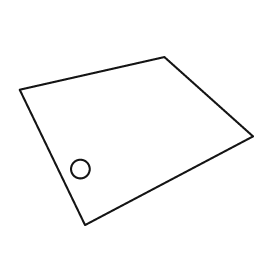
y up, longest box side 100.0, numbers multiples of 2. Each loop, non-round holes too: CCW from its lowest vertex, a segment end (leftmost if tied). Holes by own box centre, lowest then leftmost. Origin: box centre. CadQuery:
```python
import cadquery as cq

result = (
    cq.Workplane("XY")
    .moveTo(-22.0, -36.0)
    .lineTo(50.0, 2.0)
    .lineTo(12.0, 36.0)
    .lineTo(-50.0, 22.0)
    .close()
    .moveTo(-24.0, -12.0)
    .circle(4.0)
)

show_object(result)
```